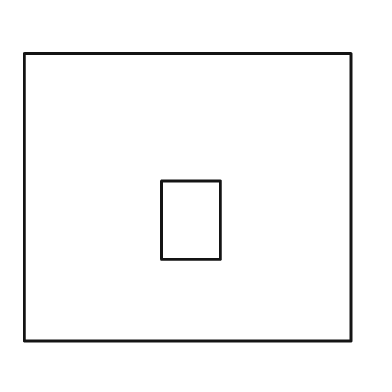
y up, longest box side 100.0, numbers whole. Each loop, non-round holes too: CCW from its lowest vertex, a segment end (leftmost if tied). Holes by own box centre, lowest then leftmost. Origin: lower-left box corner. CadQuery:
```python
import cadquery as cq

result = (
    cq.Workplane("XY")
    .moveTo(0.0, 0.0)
    .lineTo(100.0, 0.0)
    .lineTo(100.0, 88.0)
    .lineTo(0.0, 88.0)
    .close()
    .moveTo(42.0, 25.0)
    .lineTo(60.0, 25.0)
    .lineTo(60.0, 49.0)
    .lineTo(42.0, 49.0)
    .close()
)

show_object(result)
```